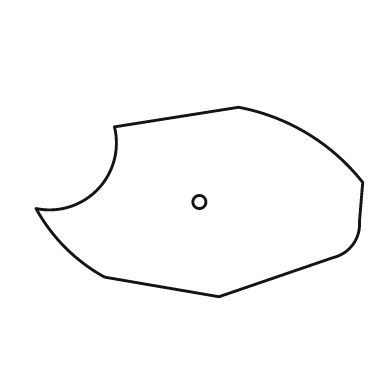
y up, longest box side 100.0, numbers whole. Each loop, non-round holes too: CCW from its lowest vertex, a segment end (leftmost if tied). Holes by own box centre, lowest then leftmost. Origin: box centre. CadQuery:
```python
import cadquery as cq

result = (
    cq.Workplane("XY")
    .moveTo(6.0, -29.0)
    .lineTo(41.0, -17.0)
    .threePointArc((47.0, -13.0), (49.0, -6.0))
    .lineTo(50.0, 6.0)
    .threePointArc((33.0, 21.0), (12.0, 29.0))
    .lineTo(-26.0, 23.0)
    .threePointArc((-31.0, 4.0), (-50.0, -2.0))
    .threePointArc((-41.0, -14.0), (-29.0, -23.0))
    .close()
    .moveTo(0.0, 0.0)
    .circle(2.0)
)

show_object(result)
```